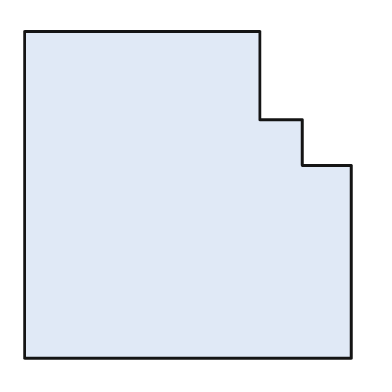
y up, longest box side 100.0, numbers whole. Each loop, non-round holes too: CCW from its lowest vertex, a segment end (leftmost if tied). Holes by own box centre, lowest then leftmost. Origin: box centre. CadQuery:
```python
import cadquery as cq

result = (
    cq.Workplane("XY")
    .moveTo(-50.0, -50.0)
    .lineTo(50.0, -50.0)
    .lineTo(50.0, 9.0)
    .lineTo(35.0, 9.0)
    .lineTo(35.0, 23.0)
    .lineTo(22.0, 23.0)
    .lineTo(22.0, 50.0)
    .lineTo(-50.0, 50.0)
    .close()
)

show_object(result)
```